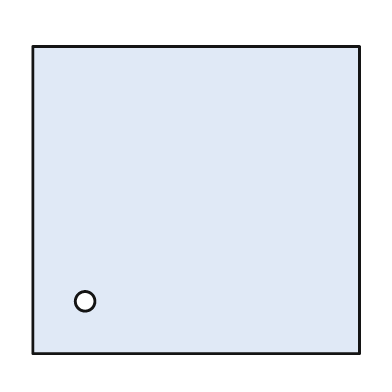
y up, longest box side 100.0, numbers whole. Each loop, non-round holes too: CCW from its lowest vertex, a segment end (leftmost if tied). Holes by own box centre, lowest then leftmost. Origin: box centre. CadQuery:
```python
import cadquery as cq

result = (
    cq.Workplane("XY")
    .moveTo(-50.0, -47.0)
    .lineTo(50.0, -47.0)
    .lineTo(50.0, 47.0)
    .lineTo(-50.0, 47.0)
    .close()
    .moveTo(-34.0, -31.0)
    .circle(3.0)
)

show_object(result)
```